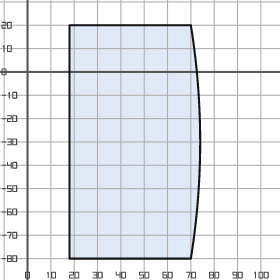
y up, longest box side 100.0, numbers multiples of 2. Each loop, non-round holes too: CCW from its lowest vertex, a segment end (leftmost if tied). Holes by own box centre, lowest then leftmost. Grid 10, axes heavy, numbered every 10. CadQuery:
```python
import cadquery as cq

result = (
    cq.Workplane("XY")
    .moveTo(18.0, -80.0)
    .lineTo(70.0, -80.0)
    .threePointArc((74.0, -30.0), (70.0, 20.0))
    .lineTo(18.0, 20.0)
    .close()
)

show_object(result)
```